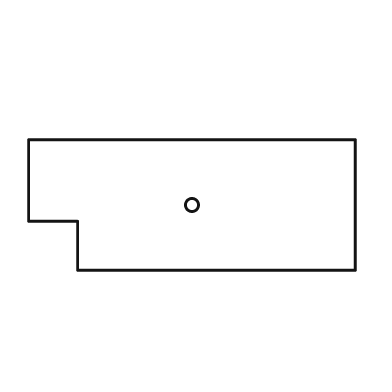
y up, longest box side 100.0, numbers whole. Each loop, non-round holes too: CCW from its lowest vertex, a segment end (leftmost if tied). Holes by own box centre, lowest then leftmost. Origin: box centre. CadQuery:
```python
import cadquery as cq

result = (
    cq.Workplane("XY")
    .moveTo(-35.0, -20.0)
    .lineTo(50.0, -20.0)
    .lineTo(50.0, 20.0)
    .lineTo(-50.0, 20.0)
    .lineTo(-50.0, -5.0)
    .lineTo(-35.0, -5.0)
    .close()
    .moveTo(0.0, 0.0)
    .circle(2.0)
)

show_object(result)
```